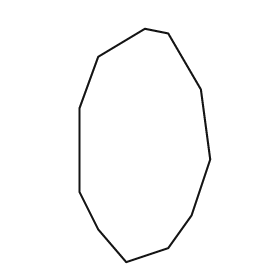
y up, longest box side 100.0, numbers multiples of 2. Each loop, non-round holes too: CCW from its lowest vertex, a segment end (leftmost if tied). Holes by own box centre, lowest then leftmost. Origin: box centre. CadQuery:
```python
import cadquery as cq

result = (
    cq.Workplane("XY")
    .moveTo(-8.0, -50.0)
    .lineTo(10.0, -44.0)
    .lineTo(20.0, -30.0)
    .lineTo(28.0, -6.0)
    .lineTo(24.0, 24.0)
    .lineTo(10.0, 48.0)
    .lineTo(0.0, 50.0)
    .lineTo(-20.0, 38.0)
    .lineTo(-28.0, 16.0)
    .lineTo(-28.0, -20.0)
    .lineTo(-20.0, -36.0)
    .close()
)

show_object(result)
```